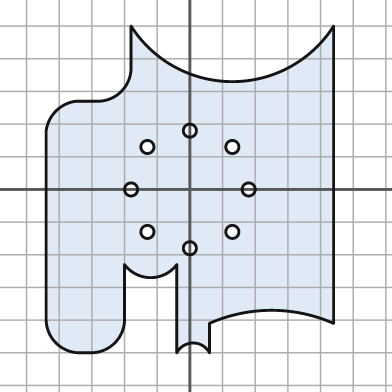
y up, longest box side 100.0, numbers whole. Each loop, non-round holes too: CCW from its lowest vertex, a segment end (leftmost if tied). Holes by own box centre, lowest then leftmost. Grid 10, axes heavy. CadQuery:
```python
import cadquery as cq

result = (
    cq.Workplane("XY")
    .moveTo(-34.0, -50.0)
    .lineTo(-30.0, -50.0)
    .threePointArc((-23.0, -47.0), (-20.0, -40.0))
    .lineTo(-20.0, -23.0)
    .threePointArc((-12.0, -27.0), (-4.0, -23.0))
    .lineTo(-4.0, -50.0)
    .threePointArc((1.0, -47.0), (6.0, -50.0))
    .lineTo(6.0, -41.0)
    .threePointArc((25.0, -37.0), (44.0, -41.0))
    .lineTo(44.0, 50.0)
    .threePointArc((13.0, 33.0), (-18.0, 50.0))
    .lineTo(-18.0, 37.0)
    .threePointArc((-21.0, 30.0), (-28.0, 27.0))
    .lineTo(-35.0, 27.0)
    .threePointArc((-41.0, 24.0), (-44.0, 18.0))
    .lineTo(-44.0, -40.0)
    .threePointArc((-41.0, -47.0), (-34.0, -50.0))
    .close()
    .moveTo(0.0, -18.0)
    .circle(2.0)
    .moveTo(-13.0, -13.0)
    .circle(2.0)
    .moveTo(13.0, -13.0)
    .circle(2.0)
    .moveTo(-18.0, 0.0)
    .circle(2.0)
    .moveTo(18.0, 0.0)
    .circle(2.0)
    .moveTo(-13.0, 13.0)
    .circle(2.0)
    .moveTo(13.0, 13.0)
    .circle(2.0)
    .moveTo(0.0, 18.0)
    .circle(2.0)
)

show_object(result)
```